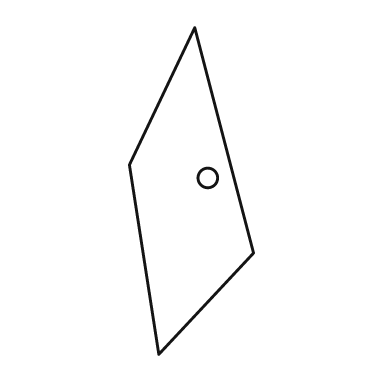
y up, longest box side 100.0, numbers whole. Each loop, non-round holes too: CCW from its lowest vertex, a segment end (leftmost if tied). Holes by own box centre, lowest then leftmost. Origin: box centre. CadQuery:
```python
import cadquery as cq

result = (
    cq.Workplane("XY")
    .moveTo(-10.0, -50.0)
    .lineTo(19.0, -19.0)
    .lineTo(1.0, 50.0)
    .lineTo(-19.0, 8.0)
    .close()
    .moveTo(5.0, 4.0)
    .circle(3.0)
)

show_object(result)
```